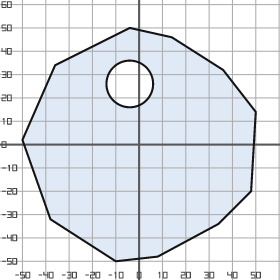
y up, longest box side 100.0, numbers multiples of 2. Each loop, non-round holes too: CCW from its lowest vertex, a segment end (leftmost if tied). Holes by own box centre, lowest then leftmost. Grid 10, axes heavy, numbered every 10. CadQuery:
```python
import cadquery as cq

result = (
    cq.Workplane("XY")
    .moveTo(-10.0, -50.0)
    .lineTo(8.0, -48.0)
    .lineTo(34.0, -34.0)
    .lineTo(48.0, -20.0)
    .lineTo(50.0, 14.0)
    .lineTo(36.0, 32.0)
    .lineTo(14.0, 46.0)
    .lineTo(-4.0, 50.0)
    .lineTo(-36.0, 34.0)
    .lineTo(-50.0, 2.0)
    .lineTo(-38.0, -32.0)
    .close()
    .moveTo(-4.0, 26.0)
    .circle(10.0)
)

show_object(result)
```